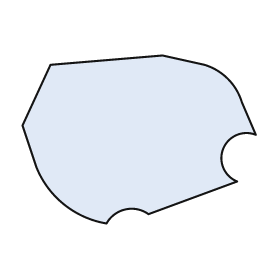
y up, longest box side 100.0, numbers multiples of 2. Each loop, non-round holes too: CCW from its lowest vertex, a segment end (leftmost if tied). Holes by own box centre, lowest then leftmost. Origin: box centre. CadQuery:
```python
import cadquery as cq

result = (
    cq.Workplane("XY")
    .moveTo(-14.0, -36.0)
    .threePointArc((-6.0, -30.0), (4.0, -32.0))
    .lineTo(42.0, -18.0)
    .threePointArc((36.0, -4.0), (50.0, 2.0))
    .lineTo(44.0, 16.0)
    .threePointArc((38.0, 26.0), (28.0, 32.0))
    .lineTo(10.0, 36.0)
    .lineTo(-38.0, 32.0)
    .lineTo(-50.0, 6.0)
    .lineTo(-44.0, -12.0)
    .threePointArc((-32.0, -28.0), (-14.0, -36.0))
    .close()
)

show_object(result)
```